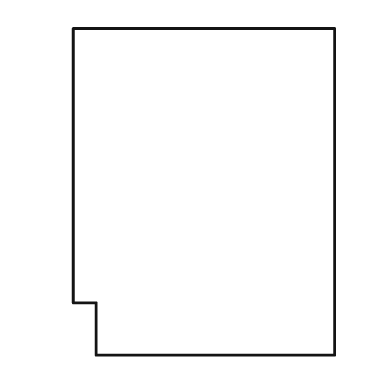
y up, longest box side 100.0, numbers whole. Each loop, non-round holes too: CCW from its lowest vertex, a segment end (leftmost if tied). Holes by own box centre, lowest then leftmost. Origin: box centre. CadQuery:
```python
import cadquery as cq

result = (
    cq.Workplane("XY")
    .moveTo(-33.0, -50.0)
    .lineTo(40.0, -50.0)
    .lineTo(40.0, 50.0)
    .lineTo(-40.0, 50.0)
    .lineTo(-40.0, -34.0)
    .lineTo(-33.0, -34.0)
    .close()
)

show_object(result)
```